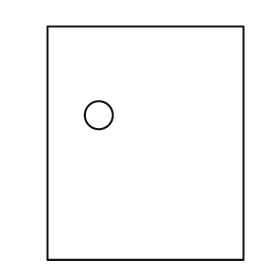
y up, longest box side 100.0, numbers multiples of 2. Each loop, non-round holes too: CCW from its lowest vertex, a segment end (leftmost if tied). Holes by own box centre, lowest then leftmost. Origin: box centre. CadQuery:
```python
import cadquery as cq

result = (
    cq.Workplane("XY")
    .moveTo(-42.0, -50.0)
    .lineTo(42.0, -50.0)
    .lineTo(42.0, 50.0)
    .lineTo(-42.0, 50.0)
    .close()
    .moveTo(-20.0, 12.0)
    .circle(6.0)
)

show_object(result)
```